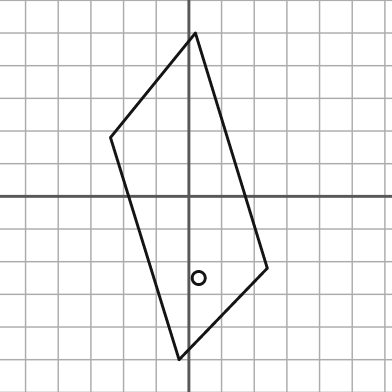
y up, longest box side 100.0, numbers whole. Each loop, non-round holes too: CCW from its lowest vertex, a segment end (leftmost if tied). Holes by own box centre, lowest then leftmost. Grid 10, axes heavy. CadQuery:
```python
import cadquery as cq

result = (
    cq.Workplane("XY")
    .moveTo(-3.0, -50.0)
    .lineTo(24.0, -22.0)
    .lineTo(2.0, 50.0)
    .lineTo(-24.0, 18.0)
    .close()
    .moveTo(3.0, -25.0)
    .circle(2.0)
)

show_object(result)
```